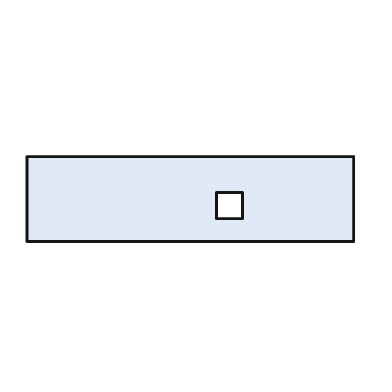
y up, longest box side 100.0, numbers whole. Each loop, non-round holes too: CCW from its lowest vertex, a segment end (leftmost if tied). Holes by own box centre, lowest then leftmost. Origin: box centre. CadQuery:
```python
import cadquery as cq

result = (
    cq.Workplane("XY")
    .moveTo(-50.0, -13.0)
    .lineTo(50.0, -13.0)
    .lineTo(50.0, 13.0)
    .lineTo(-50.0, 13.0)
    .close()
    .moveTo(8.0, -6.0)
    .lineTo(16.0, -6.0)
    .lineTo(16.0, 2.0)
    .lineTo(8.0, 2.0)
    .close()
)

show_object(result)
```